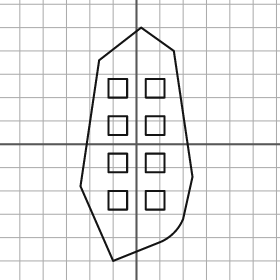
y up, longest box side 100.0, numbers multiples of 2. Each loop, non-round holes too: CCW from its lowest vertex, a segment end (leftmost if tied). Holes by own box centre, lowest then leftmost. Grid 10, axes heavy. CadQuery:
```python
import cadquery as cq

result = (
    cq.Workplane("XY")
    .moveTo(-10.0, -50.0)
    .lineTo(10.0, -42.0)
    .threePointArc((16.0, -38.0), (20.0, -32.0))
    .lineTo(24.0, -14.0)
    .lineTo(16.0, 40.0)
    .lineTo(2.0, 50.0)
    .lineTo(-16.0, 36.0)
    .lineTo(-24.0, -18.0)
    .close()
    .moveTo(-12.0, -28.0)
    .lineTo(-4.0, -28.0)
    .lineTo(-4.0, -20.0)
    .lineTo(-12.0, -20.0)
    .close()
    .moveTo(4.0, -28.0)
    .lineTo(12.0, -28.0)
    .lineTo(12.0, -20.0)
    .lineTo(4.0, -20.0)
    .close()
    .moveTo(-12.0, -12.0)
    .lineTo(-4.0, -12.0)
    .lineTo(-4.0, -4.0)
    .lineTo(-12.0, -4.0)
    .close()
    .moveTo(4.0, -12.0)
    .lineTo(12.0, -12.0)
    .lineTo(12.0, -4.0)
    .lineTo(4.0, -4.0)
    .close()
    .moveTo(-12.0, 4.0)
    .lineTo(-4.0, 4.0)
    .lineTo(-4.0, 12.0)
    .lineTo(-12.0, 12.0)
    .close()
    .moveTo(4.0, 4.0)
    .lineTo(12.0, 4.0)
    .lineTo(12.0, 12.0)
    .lineTo(4.0, 12.0)
    .close()
    .moveTo(-12.0, 20.0)
    .lineTo(-4.0, 20.0)
    .lineTo(-4.0, 28.0)
    .lineTo(-12.0, 28.0)
    .close()
    .moveTo(4.0, 20.0)
    .lineTo(12.0, 20.0)
    .lineTo(12.0, 28.0)
    .lineTo(4.0, 28.0)
    .close()
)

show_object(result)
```